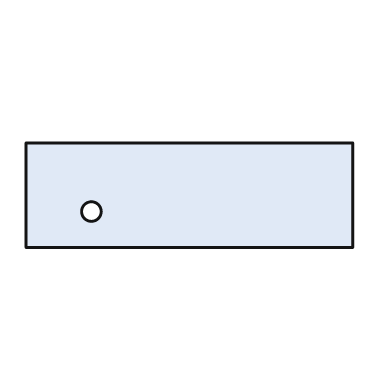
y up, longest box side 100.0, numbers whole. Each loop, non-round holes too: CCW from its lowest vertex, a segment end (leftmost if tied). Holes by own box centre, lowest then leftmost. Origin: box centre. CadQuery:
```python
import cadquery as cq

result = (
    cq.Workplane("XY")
    .moveTo(-50.0, -16.0)
    .lineTo(50.0, -16.0)
    .lineTo(50.0, 16.0)
    .lineTo(-50.0, 16.0)
    .close()
    .moveTo(-30.0, -5.0)
    .circle(3.0)
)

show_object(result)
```